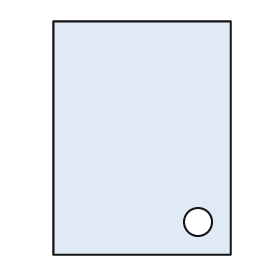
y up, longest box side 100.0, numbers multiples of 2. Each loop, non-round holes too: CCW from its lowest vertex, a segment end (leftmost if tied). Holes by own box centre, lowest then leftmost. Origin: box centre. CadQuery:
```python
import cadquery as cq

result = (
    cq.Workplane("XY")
    .moveTo(-38.0, -50.0)
    .lineTo(38.0, -50.0)
    .lineTo(38.0, 50.0)
    .lineTo(-38.0, 50.0)
    .close()
    .moveTo(24.0, -36.0)
    .circle(6.0)
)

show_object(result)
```